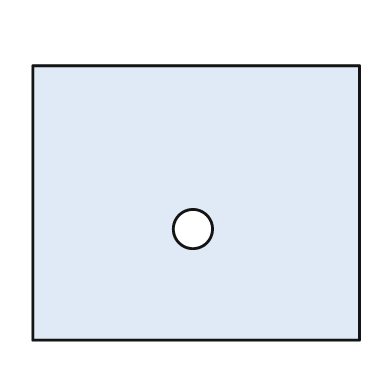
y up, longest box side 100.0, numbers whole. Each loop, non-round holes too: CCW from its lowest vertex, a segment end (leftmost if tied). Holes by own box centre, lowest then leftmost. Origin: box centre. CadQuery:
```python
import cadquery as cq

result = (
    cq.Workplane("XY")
    .moveTo(-50.0, -42.0)
    .lineTo(50.0, -42.0)
    .lineTo(50.0, 42.0)
    .lineTo(-50.0, 42.0)
    .close()
    .moveTo(-1.0, -8.0)
    .circle(6.0)
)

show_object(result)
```